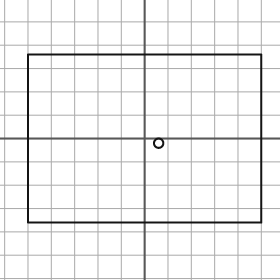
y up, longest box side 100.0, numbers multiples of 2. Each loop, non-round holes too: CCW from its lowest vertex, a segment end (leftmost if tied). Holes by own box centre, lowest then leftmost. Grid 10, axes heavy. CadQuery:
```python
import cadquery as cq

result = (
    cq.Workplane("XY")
    .moveTo(-50.0, -36.0)
    .lineTo(50.0, -36.0)
    .lineTo(50.0, 36.0)
    .lineTo(-50.0, 36.0)
    .close()
    .moveTo(6.0, -2.0)
    .circle(2.0)
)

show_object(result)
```